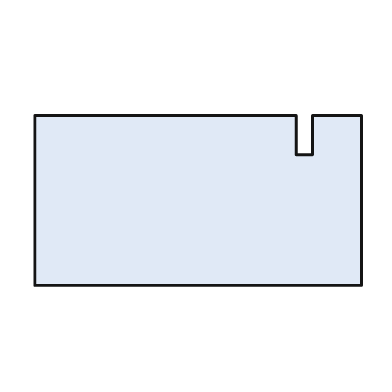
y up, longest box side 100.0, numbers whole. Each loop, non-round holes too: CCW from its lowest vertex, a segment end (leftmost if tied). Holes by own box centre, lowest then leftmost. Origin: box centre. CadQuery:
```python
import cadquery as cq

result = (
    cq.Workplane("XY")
    .moveTo(-50.0, -26.0)
    .lineTo(50.0, -26.0)
    .lineTo(50.0, 26.0)
    .lineTo(35.0, 26.0)
    .lineTo(35.0, 14.0)
    .lineTo(30.0, 14.0)
    .lineTo(30.0, 26.0)
    .lineTo(-50.0, 26.0)
    .close()
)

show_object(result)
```